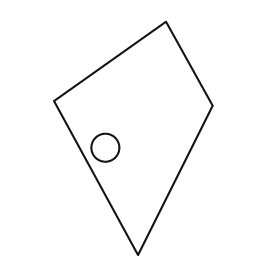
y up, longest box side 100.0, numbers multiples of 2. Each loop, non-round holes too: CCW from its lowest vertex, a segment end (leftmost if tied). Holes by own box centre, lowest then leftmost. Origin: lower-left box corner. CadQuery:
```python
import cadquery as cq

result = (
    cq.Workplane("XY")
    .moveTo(36.0, 0.0)
    .lineTo(68.0, 64.0)
    .lineTo(48.0, 100.0)
    .lineTo(0.0, 66.0)
    .close()
    .moveTo(22.0, 46.0)
    .circle(6.0)
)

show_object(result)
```